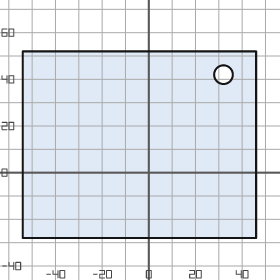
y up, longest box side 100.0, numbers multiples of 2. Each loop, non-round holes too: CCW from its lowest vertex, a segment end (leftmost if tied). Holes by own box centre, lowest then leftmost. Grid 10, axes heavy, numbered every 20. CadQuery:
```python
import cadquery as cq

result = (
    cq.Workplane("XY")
    .moveTo(-54.0, -28.0)
    .lineTo(46.0, -28.0)
    .lineTo(46.0, 52.0)
    .lineTo(-54.0, 52.0)
    .close()
    .moveTo(32.0, 42.0)
    .circle(4.0)
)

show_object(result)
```